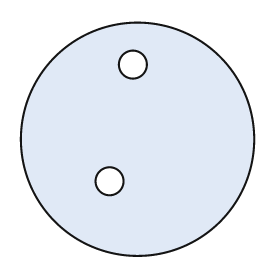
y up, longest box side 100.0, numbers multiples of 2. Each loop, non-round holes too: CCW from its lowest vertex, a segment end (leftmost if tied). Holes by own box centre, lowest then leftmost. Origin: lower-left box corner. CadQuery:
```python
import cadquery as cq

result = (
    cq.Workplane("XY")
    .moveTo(50.0, 50.0)
    .circle(50.0)
    .moveTo(38.0, 32.0)
    .circle(6.0)
    .moveTo(48.0, 82.0)
    .circle(6.0)
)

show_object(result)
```